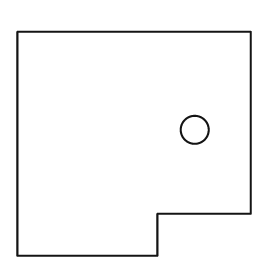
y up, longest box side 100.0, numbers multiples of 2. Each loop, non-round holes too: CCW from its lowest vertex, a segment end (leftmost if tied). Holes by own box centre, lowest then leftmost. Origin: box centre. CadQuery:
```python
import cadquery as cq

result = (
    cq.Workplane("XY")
    .moveTo(-50.0, -48.0)
    .lineTo(10.0, -48.0)
    .lineTo(10.0, -30.0)
    .lineTo(50.0, -30.0)
    .lineTo(50.0, 48.0)
    .lineTo(-50.0, 48.0)
    .close()
    .moveTo(26.0, 6.0)
    .circle(6.0)
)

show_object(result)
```